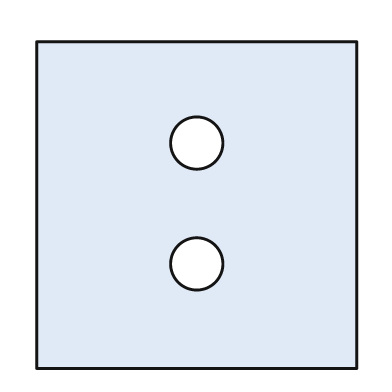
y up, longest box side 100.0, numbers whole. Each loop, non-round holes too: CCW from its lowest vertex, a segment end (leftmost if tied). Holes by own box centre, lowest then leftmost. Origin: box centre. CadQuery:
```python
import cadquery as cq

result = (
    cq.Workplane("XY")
    .moveTo(-49.0, -50.0)
    .lineTo(49.0, -50.0)
    .lineTo(49.0, 50.0)
    .lineTo(-49.0, 50.0)
    .close()
    .moveTo(0.0, -18.0)
    .circle(8.0)
    .moveTo(0.0, 19.0)
    .circle(8.0)
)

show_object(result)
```